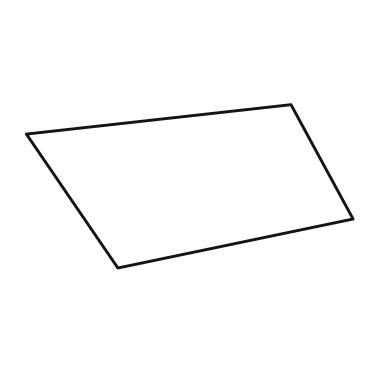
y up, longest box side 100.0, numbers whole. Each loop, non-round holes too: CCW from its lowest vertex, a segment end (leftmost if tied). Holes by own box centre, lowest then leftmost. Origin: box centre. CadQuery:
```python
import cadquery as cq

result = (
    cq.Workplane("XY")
    .moveTo(-22.0, -25.0)
    .lineTo(50.0, -10.0)
    .lineTo(31.0, 25.0)
    .lineTo(-50.0, 16.0)
    .close()
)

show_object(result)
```